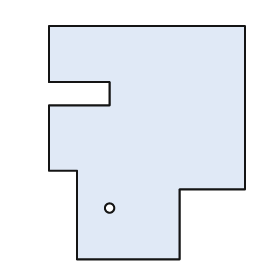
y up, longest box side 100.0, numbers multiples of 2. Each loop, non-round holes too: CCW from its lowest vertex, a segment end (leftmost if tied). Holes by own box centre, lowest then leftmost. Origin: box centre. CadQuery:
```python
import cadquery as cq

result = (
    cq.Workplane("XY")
    .moveTo(-30.0, -50.0)
    .lineTo(14.0, -50.0)
    .lineTo(14.0, -20.0)
    .lineTo(42.0, -20.0)
    .lineTo(42.0, 50.0)
    .lineTo(-42.0, 50.0)
    .lineTo(-42.0, 26.0)
    .lineTo(-16.0, 26.0)
    .lineTo(-16.0, 16.0)
    .lineTo(-42.0, 16.0)
    .lineTo(-42.0, -12.0)
    .lineTo(-30.0, -12.0)
    .close()
    .moveTo(-16.0, -28.0)
    .circle(2.0)
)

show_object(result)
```